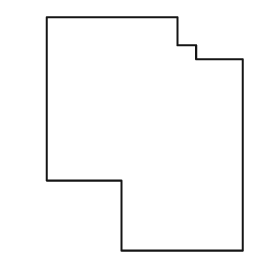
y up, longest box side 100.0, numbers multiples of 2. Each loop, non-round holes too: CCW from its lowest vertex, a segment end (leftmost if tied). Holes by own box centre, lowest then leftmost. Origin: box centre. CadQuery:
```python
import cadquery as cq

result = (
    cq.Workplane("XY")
    .moveTo(-10.0, -50.0)
    .lineTo(42.0, -50.0)
    .lineTo(42.0, 32.0)
    .lineTo(22.0, 32.0)
    .lineTo(22.0, 38.0)
    .lineTo(14.0, 38.0)
    .lineTo(14.0, 50.0)
    .lineTo(-42.0, 50.0)
    .lineTo(-42.0, -20.0)
    .lineTo(-10.0, -20.0)
    .close()
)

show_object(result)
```